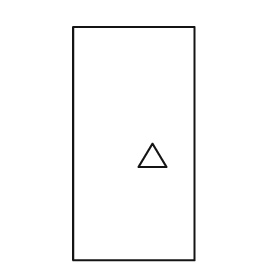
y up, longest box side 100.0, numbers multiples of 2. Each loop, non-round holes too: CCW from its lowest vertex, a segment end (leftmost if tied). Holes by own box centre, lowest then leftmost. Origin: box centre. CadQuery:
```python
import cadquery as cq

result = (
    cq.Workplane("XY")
    .moveTo(-26.0, -50.0)
    .lineTo(26.0, -50.0)
    .lineTo(26.0, 50.0)
    .lineTo(-26.0, 50.0)
    .close()
    .moveTo(2.0, -10.0)
    .lineTo(14.0, -10.0)
    .lineTo(8.0, 0.0)
    .close()
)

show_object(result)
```